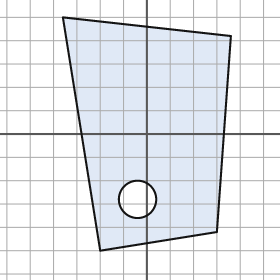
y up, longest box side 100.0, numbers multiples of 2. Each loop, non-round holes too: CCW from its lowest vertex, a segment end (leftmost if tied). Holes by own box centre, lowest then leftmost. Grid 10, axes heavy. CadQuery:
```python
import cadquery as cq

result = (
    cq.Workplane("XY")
    .moveTo(-20.0, -50.0)
    .lineTo(30.0, -42.0)
    .lineTo(36.0, 42.0)
    .lineTo(-36.0, 50.0)
    .close()
    .moveTo(-4.0, -28.0)
    .circle(8.0)
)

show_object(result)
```